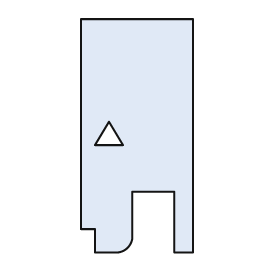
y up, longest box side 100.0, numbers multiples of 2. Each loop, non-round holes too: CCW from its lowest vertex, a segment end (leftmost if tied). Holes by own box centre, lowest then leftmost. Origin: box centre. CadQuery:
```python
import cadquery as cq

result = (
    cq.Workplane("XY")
    .moveTo(-18.0, -50.0)
    .lineTo(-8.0, -50.0)
    .threePointArc((-4.0, -48.0), (-2.0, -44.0))
    .lineTo(-2.0, -24.0)
    .lineTo(16.0, -24.0)
    .lineTo(16.0, -50.0)
    .lineTo(24.0, -50.0)
    .lineTo(24.0, 50.0)
    .lineTo(-24.0, 50.0)
    .lineTo(-24.0, -40.0)
    .lineTo(-18.0, -40.0)
    .close()
    .moveTo(-18.0, -4.0)
    .lineTo(-6.0, -4.0)
    .lineTo(-12.0, 6.0)
    .close()
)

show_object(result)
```